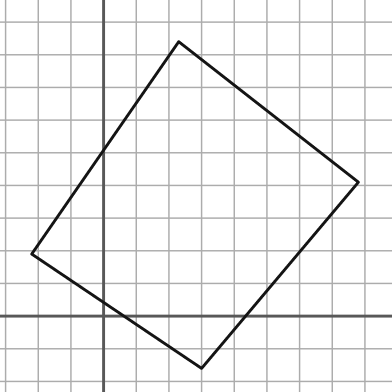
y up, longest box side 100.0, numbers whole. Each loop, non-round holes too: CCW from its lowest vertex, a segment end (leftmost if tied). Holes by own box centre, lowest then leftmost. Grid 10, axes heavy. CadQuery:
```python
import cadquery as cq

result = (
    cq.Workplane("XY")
    .moveTo(30.0, -16.0)
    .lineTo(78.0, 41.0)
    .lineTo(23.0, 84.0)
    .lineTo(-22.0, 19.0)
    .close()
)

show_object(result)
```